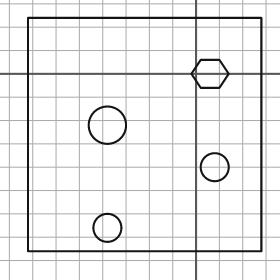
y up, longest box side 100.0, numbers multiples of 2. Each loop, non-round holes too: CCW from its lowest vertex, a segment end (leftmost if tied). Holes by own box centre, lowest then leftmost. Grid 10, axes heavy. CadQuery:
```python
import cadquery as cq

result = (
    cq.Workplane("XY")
    .moveTo(-72.0, -76.0)
    .lineTo(28.0, -76.0)
    .lineTo(28.0, 24.0)
    .lineTo(-72.0, 24.0)
    .close()
    .moveTo(-38.0, -66.0)
    .circle(6.0)
    .moveTo(8.0, -40.0)
    .circle(6.0)
    .moveTo(-38.0, -22.0)
    .circle(8.0)
    .moveTo(2.0, -6.0)
    .lineTo(10.0, -6.0)
    .lineTo(14.0, 0.0)
    .lineTo(10.0, 6.0)
    .lineTo(2.0, 6.0)
    .lineTo(-2.0, 0.0)
    .close()
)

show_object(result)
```